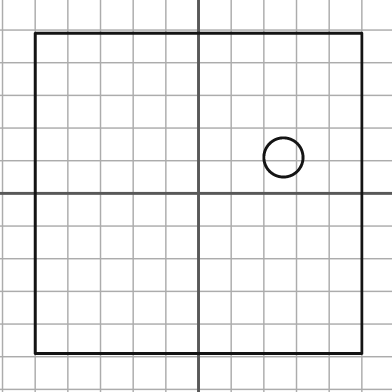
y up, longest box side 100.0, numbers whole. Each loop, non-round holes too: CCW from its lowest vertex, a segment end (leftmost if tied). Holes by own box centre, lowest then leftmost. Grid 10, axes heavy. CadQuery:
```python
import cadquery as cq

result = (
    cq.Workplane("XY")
    .moveTo(-50.0, -49.0)
    .lineTo(50.0, -49.0)
    .lineTo(50.0, 49.0)
    .lineTo(-50.0, 49.0)
    .close()
    .moveTo(26.0, 11.0)
    .circle(6.0)
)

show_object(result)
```